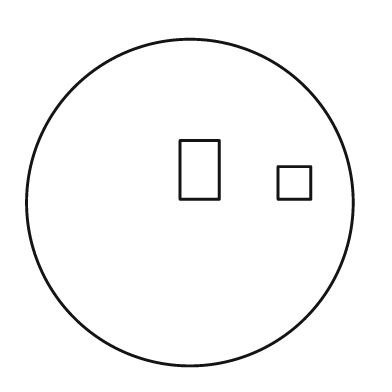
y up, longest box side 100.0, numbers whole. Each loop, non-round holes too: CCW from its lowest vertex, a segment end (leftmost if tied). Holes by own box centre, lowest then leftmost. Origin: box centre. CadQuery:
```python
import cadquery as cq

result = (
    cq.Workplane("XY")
    .moveTo(0.0, 0.0)
    .circle(50.0)
    .moveTo(27.0, 1.0)
    .lineTo(37.0, 1.0)
    .lineTo(37.0, 11.0)
    .lineTo(27.0, 11.0)
    .close()
    .moveTo(-3.0, 1.0)
    .lineTo(9.0, 1.0)
    .lineTo(9.0, 19.0)
    .lineTo(-3.0, 19.0)
    .close()
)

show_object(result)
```